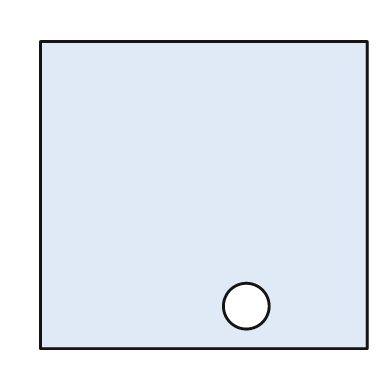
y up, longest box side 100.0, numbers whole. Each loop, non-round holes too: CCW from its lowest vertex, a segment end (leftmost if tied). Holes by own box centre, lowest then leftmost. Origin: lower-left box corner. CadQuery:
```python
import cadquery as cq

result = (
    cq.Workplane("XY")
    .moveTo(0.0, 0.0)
    .lineTo(100.0, 0.0)
    .lineTo(100.0, 94.0)
    .lineTo(0.0, 94.0)
    .close()
    .moveTo(63.0, 13.0)
    .circle(7.0)
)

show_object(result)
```